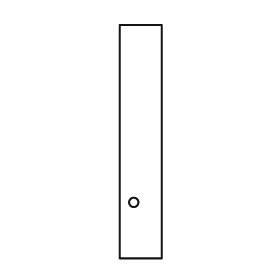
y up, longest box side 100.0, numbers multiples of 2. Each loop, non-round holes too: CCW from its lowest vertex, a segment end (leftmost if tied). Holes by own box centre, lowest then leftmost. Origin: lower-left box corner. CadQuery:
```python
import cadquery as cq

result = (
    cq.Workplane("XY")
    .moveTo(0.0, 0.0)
    .lineTo(18.0, 0.0)
    .lineTo(18.0, 100.0)
    .lineTo(0.0, 100.0)
    .close()
    .moveTo(6.0, 24.0)
    .circle(2.0)
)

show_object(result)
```